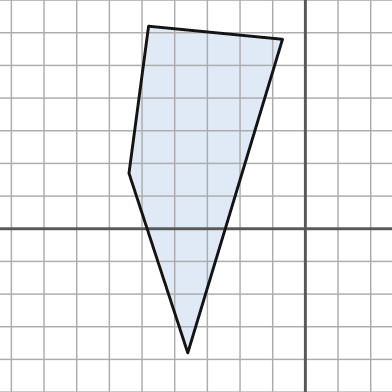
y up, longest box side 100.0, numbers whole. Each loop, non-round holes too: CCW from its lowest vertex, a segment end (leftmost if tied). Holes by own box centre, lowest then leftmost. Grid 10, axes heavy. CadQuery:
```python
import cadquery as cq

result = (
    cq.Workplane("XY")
    .moveTo(-36.0, -38.0)
    .lineTo(-7.0, 58.0)
    .lineTo(-48.0, 62.0)
    .lineTo(-54.0, 17.0)
    .close()
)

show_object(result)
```